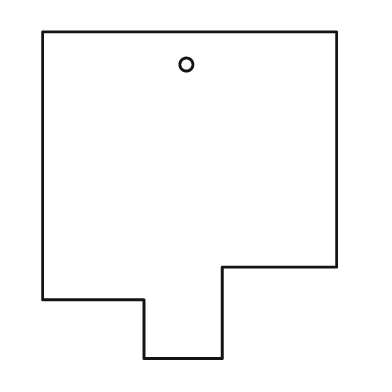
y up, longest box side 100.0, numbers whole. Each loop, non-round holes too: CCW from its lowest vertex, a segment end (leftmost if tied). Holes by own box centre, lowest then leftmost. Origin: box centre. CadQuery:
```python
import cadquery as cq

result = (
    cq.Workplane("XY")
    .moveTo(-14.0, -50.0)
    .lineTo(10.0, -50.0)
    .lineTo(10.0, -22.0)
    .lineTo(45.0, -22.0)
    .lineTo(45.0, 50.0)
    .lineTo(-45.0, 50.0)
    .lineTo(-45.0, -32.0)
    .lineTo(-14.0, -32.0)
    .close()
    .moveTo(-1.0, 40.0)
    .circle(2.0)
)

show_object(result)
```